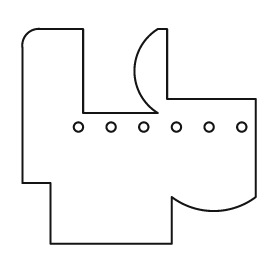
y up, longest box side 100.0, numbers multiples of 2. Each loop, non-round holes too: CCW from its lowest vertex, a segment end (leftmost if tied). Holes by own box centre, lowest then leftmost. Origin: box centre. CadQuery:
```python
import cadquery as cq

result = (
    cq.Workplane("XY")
    .moveTo(-38.0, -46.0)
    .lineTo(14.0, -46.0)
    .lineTo(14.0, -26.0)
    .threePointArc((32.0, -32.0), (50.0, -26.0))
    .lineTo(50.0, 16.0)
    .lineTo(12.0, 16.0)
    .lineTo(12.0, 46.0)
    .lineTo(8.0, 46.0)
    .threePointArc((-2.0, 28.0), (8.0, 10.0))
    .lineTo(-24.0, 10.0)
    .lineTo(-24.0, 46.0)
    .lineTo(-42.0, 46.0)
    .threePointArc((-48.0, 44.0), (-50.0, 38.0))
    .lineTo(-50.0, -20.0)
    .lineTo(-38.0, -20.0)
    .close()
    .moveTo(-26.0, 4.0)
    .circle(2.0)
    .moveTo(-12.0, 4.0)
    .circle(2.0)
    .moveTo(2.0, 4.0)
    .circle(2.0)
    .moveTo(16.0, 4.0)
    .circle(2.0)
    .moveTo(30.0, 4.0)
    .circle(2.0)
    .moveTo(44.0, 4.0)
    .circle(2.0)
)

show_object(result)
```